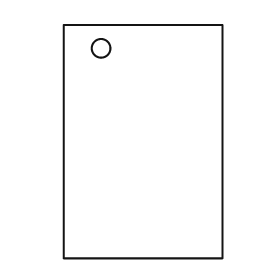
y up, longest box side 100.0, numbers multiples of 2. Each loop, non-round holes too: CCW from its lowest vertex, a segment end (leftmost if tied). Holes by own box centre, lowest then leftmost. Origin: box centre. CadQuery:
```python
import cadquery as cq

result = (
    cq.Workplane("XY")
    .moveTo(-34.0, -50.0)
    .lineTo(34.0, -50.0)
    .lineTo(34.0, 50.0)
    .lineTo(-34.0, 50.0)
    .close()
    .moveTo(-18.0, 40.0)
    .circle(4.0)
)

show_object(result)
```